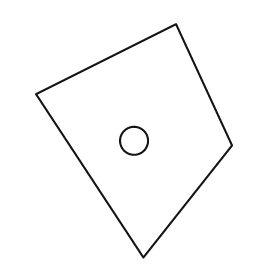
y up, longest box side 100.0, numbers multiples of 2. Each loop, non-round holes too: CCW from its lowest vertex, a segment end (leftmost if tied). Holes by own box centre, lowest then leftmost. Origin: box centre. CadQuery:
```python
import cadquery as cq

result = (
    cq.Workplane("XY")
    .moveTo(4.0, -50.0)
    .lineTo(42.0, -2.0)
    .lineTo(18.0, 50.0)
    .lineTo(-42.0, 20.0)
    .close()
    .moveTo(0.0, 0.0)
    .circle(6.0)
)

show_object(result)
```